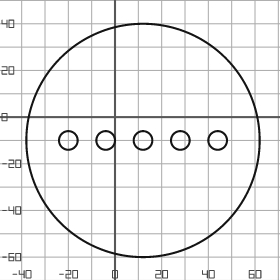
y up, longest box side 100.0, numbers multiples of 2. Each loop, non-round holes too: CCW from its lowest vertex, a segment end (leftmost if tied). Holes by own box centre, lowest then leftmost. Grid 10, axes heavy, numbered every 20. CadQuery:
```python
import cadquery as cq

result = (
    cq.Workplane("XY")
    .moveTo(12.0, -10.0)
    .circle(50.0)
    .moveTo(-20.0, -10.0)
    .circle(4.0)
    .moveTo(-4.0, -10.0)
    .circle(4.0)
    .moveTo(12.0, -10.0)
    .circle(4.0)
    .moveTo(28.0, -10.0)
    .circle(4.0)
    .moveTo(44.0, -10.0)
    .circle(4.0)
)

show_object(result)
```